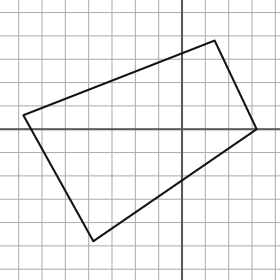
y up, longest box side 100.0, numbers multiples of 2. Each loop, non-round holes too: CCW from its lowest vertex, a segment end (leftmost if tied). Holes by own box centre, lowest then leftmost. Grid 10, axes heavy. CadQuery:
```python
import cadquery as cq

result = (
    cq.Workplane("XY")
    .moveTo(-38.0, -48.0)
    .lineTo(32.0, 0.0)
    .lineTo(14.0, 38.0)
    .lineTo(-68.0, 6.0)
    .close()
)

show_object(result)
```